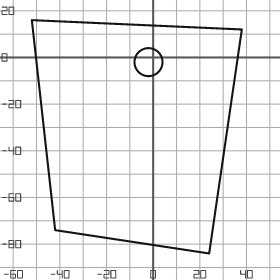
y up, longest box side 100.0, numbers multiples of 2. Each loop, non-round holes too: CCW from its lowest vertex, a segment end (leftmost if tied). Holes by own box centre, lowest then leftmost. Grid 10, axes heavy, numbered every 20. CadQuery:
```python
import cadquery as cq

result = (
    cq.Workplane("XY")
    .moveTo(24.0, -84.0)
    .lineTo(38.0, 12.0)
    .lineTo(-52.0, 16.0)
    .lineTo(-42.0, -74.0)
    .close()
    .moveTo(-2.0, -2.0)
    .circle(6.0)
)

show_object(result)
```